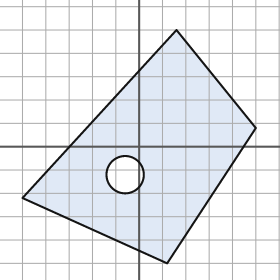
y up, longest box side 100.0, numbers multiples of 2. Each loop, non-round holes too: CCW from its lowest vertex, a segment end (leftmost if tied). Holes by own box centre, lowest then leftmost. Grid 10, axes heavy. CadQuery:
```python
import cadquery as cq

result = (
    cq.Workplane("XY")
    .moveTo(12.0, -50.0)
    .lineTo(50.0, 8.0)
    .lineTo(16.0, 50.0)
    .lineTo(-50.0, -22.0)
    .close()
    .moveTo(-6.0, -12.0)
    .circle(8.0)
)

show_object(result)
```